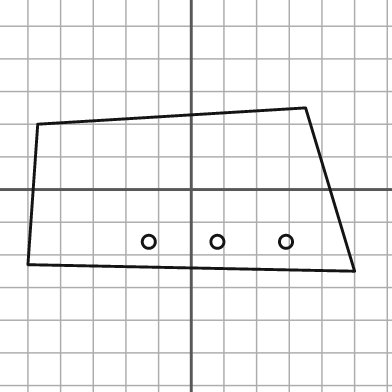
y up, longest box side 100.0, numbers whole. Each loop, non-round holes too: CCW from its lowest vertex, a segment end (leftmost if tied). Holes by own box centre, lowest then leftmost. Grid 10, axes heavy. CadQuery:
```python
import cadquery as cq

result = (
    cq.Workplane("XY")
    .moveTo(50.0, -25.0)
    .lineTo(35.0, 25.0)
    .lineTo(-47.0, 20.0)
    .lineTo(-50.0, -23.0)
    .close()
    .moveTo(-13.0, -16.0)
    .circle(2.0)
    .moveTo(8.0, -16.0)
    .circle(2.0)
    .moveTo(29.0, -16.0)
    .circle(2.0)
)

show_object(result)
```